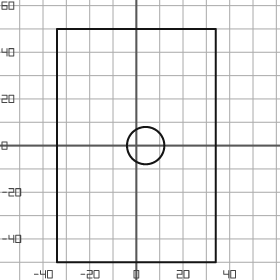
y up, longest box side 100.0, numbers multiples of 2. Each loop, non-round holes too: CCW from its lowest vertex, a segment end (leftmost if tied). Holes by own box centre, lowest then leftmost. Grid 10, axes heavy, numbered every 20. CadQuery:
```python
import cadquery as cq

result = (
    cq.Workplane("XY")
    .moveTo(-34.0, -50.0)
    .lineTo(34.0, -50.0)
    .lineTo(34.0, 50.0)
    .lineTo(-34.0, 50.0)
    .close()
    .moveTo(4.0, 0.0)
    .circle(8.0)
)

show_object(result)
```